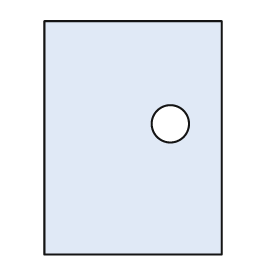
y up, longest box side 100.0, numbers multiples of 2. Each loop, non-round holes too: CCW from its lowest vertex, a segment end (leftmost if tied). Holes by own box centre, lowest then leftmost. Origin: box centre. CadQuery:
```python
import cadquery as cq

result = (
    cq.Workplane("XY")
    .moveTo(-38.0, -50.0)
    .lineTo(38.0, -50.0)
    .lineTo(38.0, 50.0)
    .lineTo(-38.0, 50.0)
    .close()
    .moveTo(16.0, 6.0)
    .circle(8.0)
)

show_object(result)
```